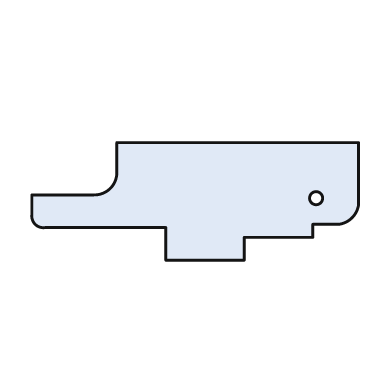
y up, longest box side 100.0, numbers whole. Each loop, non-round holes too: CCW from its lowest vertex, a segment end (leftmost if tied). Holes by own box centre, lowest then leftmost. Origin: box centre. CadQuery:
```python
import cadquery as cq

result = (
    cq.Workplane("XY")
    .moveTo(-9.0, -18.0)
    .lineTo(15.0, -18.0)
    .lineTo(15.0, -11.0)
    .lineTo(36.0, -11.0)
    .lineTo(36.0, -7.0)
    .lineTo(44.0, -7.0)
    .threePointArc((48.0, -5.0), (50.0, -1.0))
    .lineTo(50.0, 18.0)
    .lineTo(-24.0, 18.0)
    .lineTo(-24.0, 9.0)
    .threePointArc((-26.0, 4.0), (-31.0, 2.0))
    .lineTo(-50.0, 2.0)
    .lineTo(-50.0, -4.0)
    .threePointArc((-49.0, -7.0), (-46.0, -8.0))
    .lineTo(-9.0, -8.0)
    .close()
    .moveTo(37.0, 1.0)
    .circle(2.0)
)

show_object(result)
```